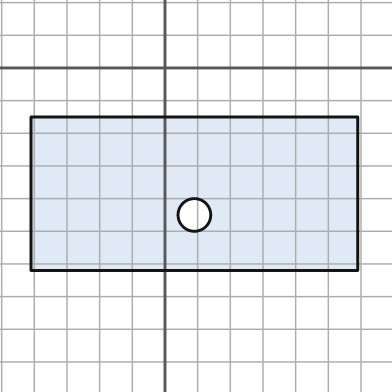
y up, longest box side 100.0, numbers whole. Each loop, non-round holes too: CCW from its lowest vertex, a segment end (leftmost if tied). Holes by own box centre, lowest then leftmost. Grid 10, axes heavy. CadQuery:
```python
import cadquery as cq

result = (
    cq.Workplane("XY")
    .moveTo(-41.0, -62.0)
    .lineTo(59.0, -62.0)
    .lineTo(59.0, -15.0)
    .lineTo(-41.0, -15.0)
    .close()
    .moveTo(9.0, -45.0)
    .circle(5.0)
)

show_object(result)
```